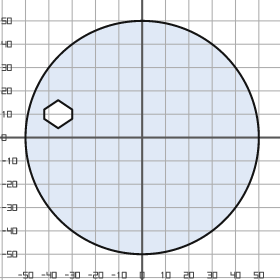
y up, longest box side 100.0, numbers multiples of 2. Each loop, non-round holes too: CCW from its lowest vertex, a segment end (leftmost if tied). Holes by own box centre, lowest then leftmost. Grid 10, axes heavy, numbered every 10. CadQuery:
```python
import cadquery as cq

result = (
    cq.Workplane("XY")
    .moveTo(0.0, 0.0)
    .circle(50.0)
    .moveTo(-36.0, 4.0)
    .lineTo(-30.0, 8.0)
    .lineTo(-30.0, 12.0)
    .lineTo(-36.0, 16.0)
    .lineTo(-42.0, 12.0)
    .lineTo(-42.0, 8.0)
    .close()
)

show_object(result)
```